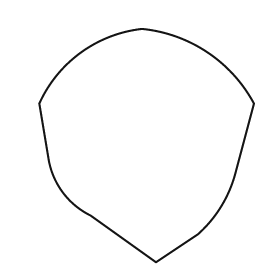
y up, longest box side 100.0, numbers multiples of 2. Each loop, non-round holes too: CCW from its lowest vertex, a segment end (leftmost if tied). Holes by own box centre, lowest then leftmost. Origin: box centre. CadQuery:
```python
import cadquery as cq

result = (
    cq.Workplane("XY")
    .moveTo(4.0, -50.0)
    .lineTo(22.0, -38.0)
    .threePointArc((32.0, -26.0), (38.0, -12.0))
    .lineTo(46.0, 18.0)
    .threePointArc((26.0, 40.0), (-2.0, 50.0))
    .threePointArc((-28.0, 40.0), (-46.0, 18.0))
    .lineTo(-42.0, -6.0)
    .threePointArc((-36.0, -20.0), (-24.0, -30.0))
    .close()
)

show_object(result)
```